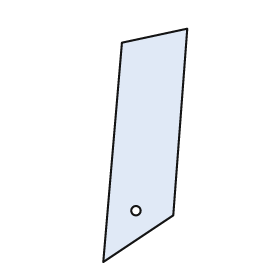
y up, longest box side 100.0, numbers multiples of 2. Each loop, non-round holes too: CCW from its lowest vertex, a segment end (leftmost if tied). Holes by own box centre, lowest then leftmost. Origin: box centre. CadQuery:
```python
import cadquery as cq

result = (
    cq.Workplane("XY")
    .moveTo(-18.0, -50.0)
    .lineTo(12.0, -30.0)
    .lineTo(18.0, 50.0)
    .lineTo(-10.0, 44.0)
    .close()
    .moveTo(-4.0, -28.0)
    .circle(2.0)
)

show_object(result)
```